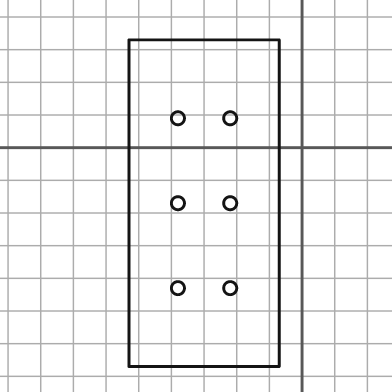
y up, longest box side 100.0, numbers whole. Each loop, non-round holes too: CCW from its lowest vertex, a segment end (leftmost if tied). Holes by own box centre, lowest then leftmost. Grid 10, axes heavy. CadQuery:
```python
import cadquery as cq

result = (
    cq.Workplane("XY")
    .moveTo(-53.0, -67.0)
    .lineTo(-7.0, -67.0)
    .lineTo(-7.0, 33.0)
    .lineTo(-53.0, 33.0)
    .close()
    .moveTo(-38.0, -43.0)
    .circle(2.0)
    .moveTo(-22.0, -43.0)
    .circle(2.0)
    .moveTo(-38.0, -17.0)
    .circle(2.0)
    .moveTo(-22.0, -17.0)
    .circle(2.0)
    .moveTo(-38.0, 9.0)
    .circle(2.0)
    .moveTo(-22.0, 9.0)
    .circle(2.0)
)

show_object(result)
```